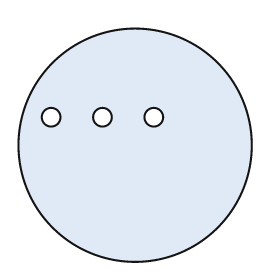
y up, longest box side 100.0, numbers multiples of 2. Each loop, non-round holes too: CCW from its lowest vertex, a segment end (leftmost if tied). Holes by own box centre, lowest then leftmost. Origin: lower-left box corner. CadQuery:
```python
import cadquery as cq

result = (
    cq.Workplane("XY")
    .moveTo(50.0, 50.0)
    .circle(50.0)
    .moveTo(14.0, 62.0)
    .circle(4.0)
    .moveTo(36.0, 62.0)
    .circle(4.0)
    .moveTo(58.0, 62.0)
    .circle(4.0)
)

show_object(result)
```